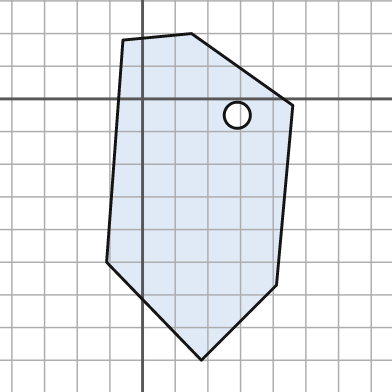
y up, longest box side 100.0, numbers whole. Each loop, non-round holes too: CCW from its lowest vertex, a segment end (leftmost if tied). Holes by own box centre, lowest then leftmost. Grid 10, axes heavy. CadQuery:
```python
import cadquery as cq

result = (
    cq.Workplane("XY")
    .moveTo(18.0, -80.0)
    .lineTo(41.0, -57.0)
    .lineTo(46.0, -2.0)
    .lineTo(15.0, 20.0)
    .lineTo(-6.0, 18.0)
    .lineTo(-11.0, -50.0)
    .close()
    .moveTo(29.0, -5.0)
    .circle(4.0)
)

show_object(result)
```